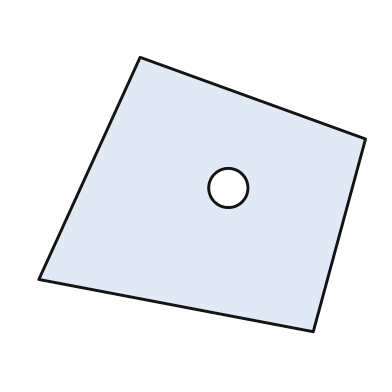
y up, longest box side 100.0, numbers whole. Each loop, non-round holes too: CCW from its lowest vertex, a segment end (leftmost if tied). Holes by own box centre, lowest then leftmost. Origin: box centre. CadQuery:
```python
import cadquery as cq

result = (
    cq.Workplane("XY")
    .moveTo(34.0, -42.0)
    .lineTo(50.0, 17.0)
    .lineTo(-19.0, 42.0)
    .lineTo(-50.0, -26.0)
    .close()
    .moveTo(8.0, 2.0)
    .circle(6.0)
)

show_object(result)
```